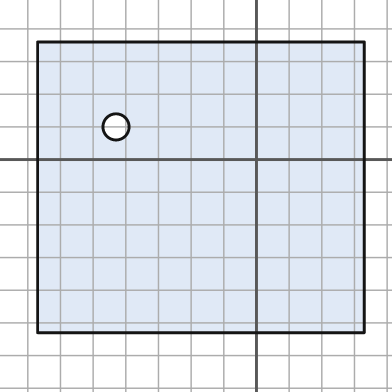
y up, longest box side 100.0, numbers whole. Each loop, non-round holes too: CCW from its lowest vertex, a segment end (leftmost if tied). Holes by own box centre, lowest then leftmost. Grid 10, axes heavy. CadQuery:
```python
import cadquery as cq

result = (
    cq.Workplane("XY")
    .moveTo(-67.0, -53.0)
    .lineTo(33.0, -53.0)
    .lineTo(33.0, 36.0)
    .lineTo(-67.0, 36.0)
    .close()
    .moveTo(-43.0, 10.0)
    .circle(4.0)
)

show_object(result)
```